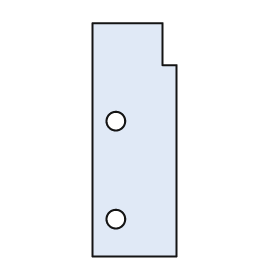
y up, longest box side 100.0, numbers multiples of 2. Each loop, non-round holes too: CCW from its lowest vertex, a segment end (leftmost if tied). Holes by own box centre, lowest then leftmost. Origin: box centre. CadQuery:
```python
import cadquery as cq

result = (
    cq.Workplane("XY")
    .moveTo(-18.0, -50.0)
    .lineTo(18.0, -50.0)
    .lineTo(18.0, 32.0)
    .lineTo(12.0, 32.0)
    .lineTo(12.0, 50.0)
    .lineTo(-18.0, 50.0)
    .close()
    .moveTo(-8.0, -34.0)
    .circle(4.0)
    .moveTo(-8.0, 8.0)
    .circle(4.0)
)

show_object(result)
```